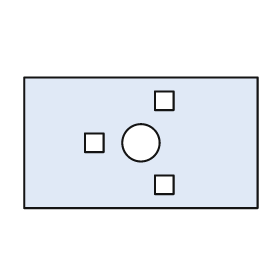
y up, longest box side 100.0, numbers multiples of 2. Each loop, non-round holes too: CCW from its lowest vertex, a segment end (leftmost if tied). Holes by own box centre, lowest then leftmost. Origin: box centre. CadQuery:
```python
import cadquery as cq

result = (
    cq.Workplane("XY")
    .moveTo(-50.0, -28.0)
    .lineTo(50.0, -28.0)
    .lineTo(50.0, 28.0)
    .lineTo(-50.0, 28.0)
    .close()
    .moveTo(6.0, -22.0)
    .lineTo(14.0, -22.0)
    .lineTo(14.0, -14.0)
    .lineTo(6.0, -14.0)
    .close()
    .moveTo(-24.0, -4.0)
    .lineTo(-16.0, -4.0)
    .lineTo(-16.0, 4.0)
    .lineTo(-24.0, 4.0)
    .close()
    .moveTo(0.0, 0.0)
    .circle(8.0)
    .moveTo(6.0, 14.0)
    .lineTo(14.0, 14.0)
    .lineTo(14.0, 22.0)
    .lineTo(6.0, 22.0)
    .close()
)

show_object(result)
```